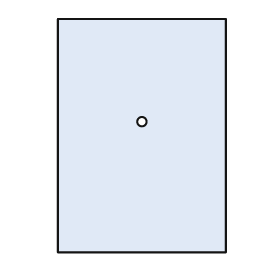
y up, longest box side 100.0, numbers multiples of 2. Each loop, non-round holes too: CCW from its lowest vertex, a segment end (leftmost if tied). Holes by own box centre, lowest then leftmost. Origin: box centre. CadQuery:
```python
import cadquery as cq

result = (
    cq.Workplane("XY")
    .moveTo(-36.0, -50.0)
    .lineTo(36.0, -50.0)
    .lineTo(36.0, 50.0)
    .lineTo(-36.0, 50.0)
    .close()
    .moveTo(0.0, 6.0)
    .circle(2.0)
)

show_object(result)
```